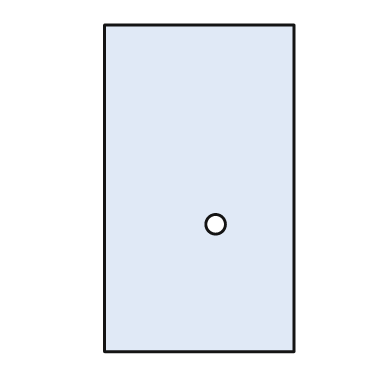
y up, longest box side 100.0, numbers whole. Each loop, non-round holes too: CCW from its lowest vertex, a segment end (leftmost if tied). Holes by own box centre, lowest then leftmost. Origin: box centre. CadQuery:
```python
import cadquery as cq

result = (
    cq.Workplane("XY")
    .moveTo(-29.0, -50.0)
    .lineTo(29.0, -50.0)
    .lineTo(29.0, 50.0)
    .lineTo(-29.0, 50.0)
    .close()
    .moveTo(5.0, -11.0)
    .circle(3.0)
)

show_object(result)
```